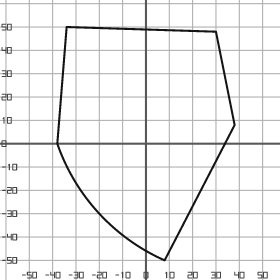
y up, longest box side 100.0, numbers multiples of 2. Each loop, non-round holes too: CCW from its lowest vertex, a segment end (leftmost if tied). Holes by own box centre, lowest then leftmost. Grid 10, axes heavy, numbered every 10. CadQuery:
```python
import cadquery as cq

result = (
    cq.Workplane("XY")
    .moveTo(8.0, -50.0)
    .lineTo(38.0, 8.0)
    .lineTo(30.0, 48.0)
    .lineTo(-34.0, 50.0)
    .lineTo(-38.0, 0.0)
    .threePointArc((-20.0, -30.0), (8.0, -50.0))
    .close()
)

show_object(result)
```